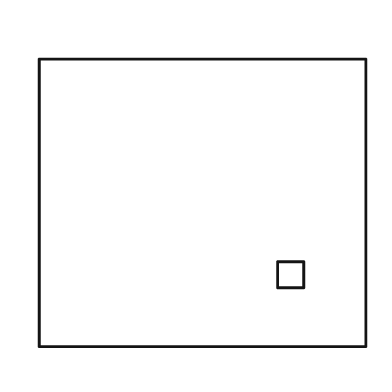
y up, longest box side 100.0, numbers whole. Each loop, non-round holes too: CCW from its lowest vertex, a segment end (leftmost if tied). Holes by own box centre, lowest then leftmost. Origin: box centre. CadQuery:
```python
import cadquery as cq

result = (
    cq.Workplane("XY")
    .moveTo(-50.0, -44.0)
    .lineTo(50.0, -44.0)
    .lineTo(50.0, 44.0)
    .lineTo(-50.0, 44.0)
    .close()
    .moveTo(23.0, -26.0)
    .lineTo(31.0, -26.0)
    .lineTo(31.0, -18.0)
    .lineTo(23.0, -18.0)
    .close()
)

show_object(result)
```